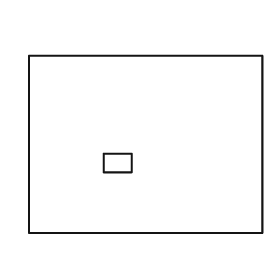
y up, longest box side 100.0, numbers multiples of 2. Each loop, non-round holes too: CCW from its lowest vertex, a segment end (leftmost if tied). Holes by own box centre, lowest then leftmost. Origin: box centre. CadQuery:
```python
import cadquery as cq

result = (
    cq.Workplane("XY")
    .moveTo(-50.0, -38.0)
    .lineTo(50.0, -38.0)
    .lineTo(50.0, 38.0)
    .lineTo(-50.0, 38.0)
    .close()
    .moveTo(-18.0, -12.0)
    .lineTo(-6.0, -12.0)
    .lineTo(-6.0, -4.0)
    .lineTo(-18.0, -4.0)
    .close()
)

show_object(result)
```